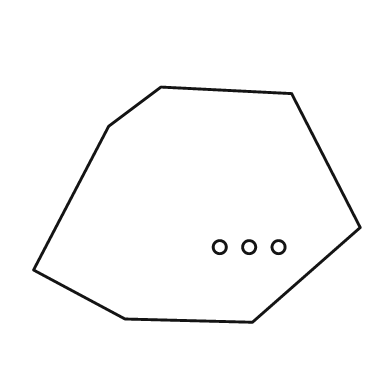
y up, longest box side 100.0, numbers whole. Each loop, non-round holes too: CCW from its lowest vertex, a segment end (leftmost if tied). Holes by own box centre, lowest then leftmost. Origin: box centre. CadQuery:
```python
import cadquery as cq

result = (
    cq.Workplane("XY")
    .moveTo(17.0, -36.0)
    .lineTo(50.0, -7.0)
    .lineTo(29.0, 34.0)
    .lineTo(-11.0, 36.0)
    .lineTo(-27.0, 24.0)
    .lineTo(-50.0, -20.0)
    .lineTo(-22.0, -35.0)
    .close()
    .moveTo(7.0, -13.0)
    .circle(2.0)
    .moveTo(16.0, -13.0)
    .circle(2.0)
    .moveTo(25.0, -13.0)
    .circle(2.0)
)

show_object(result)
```